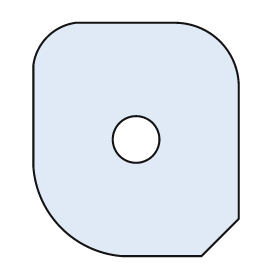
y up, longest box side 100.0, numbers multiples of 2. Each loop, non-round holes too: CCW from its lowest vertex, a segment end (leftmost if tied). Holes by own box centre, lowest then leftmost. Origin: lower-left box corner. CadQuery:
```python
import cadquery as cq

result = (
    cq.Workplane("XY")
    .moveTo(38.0, 0.0)
    .lineTo(72.0, 0.0)
    .lineTo(88.0, 16.0)
    .lineTo(88.0, 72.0)
    .threePointArc((80.0, 92.0), (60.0, 100.0))
    .lineTo(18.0, 100.0)
    .threePointArc((6.0, 94.0), (0.0, 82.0))
    .lineTo(0.0, 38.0)
    .threePointArc((12.0, 12.0), (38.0, 0.0))
    .close()
    .moveTo(44.0, 50.0)
    .circle(10.0)
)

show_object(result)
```